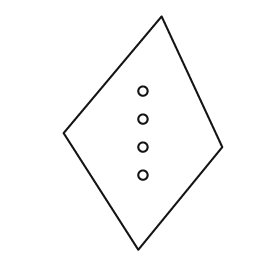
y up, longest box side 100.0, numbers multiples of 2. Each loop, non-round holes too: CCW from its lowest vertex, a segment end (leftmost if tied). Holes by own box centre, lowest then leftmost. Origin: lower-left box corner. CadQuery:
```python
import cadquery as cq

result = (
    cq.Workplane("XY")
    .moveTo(32.0, 0.0)
    .lineTo(68.0, 44.0)
    .lineTo(42.0, 100.0)
    .lineTo(0.0, 50.0)
    .close()
    .moveTo(34.0, 32.0)
    .circle(2.0)
    .moveTo(34.0, 44.0)
    .circle(2.0)
    .moveTo(34.0, 56.0)
    .circle(2.0)
    .moveTo(34.0, 68.0)
    .circle(2.0)
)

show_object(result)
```